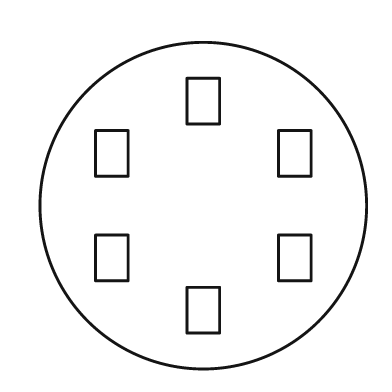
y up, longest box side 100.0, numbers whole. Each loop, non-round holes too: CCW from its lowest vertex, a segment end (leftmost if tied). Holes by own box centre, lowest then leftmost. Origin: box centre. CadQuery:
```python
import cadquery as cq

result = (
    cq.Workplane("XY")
    .moveTo(0.0, 0.0)
    .circle(50.0)
    .moveTo(-5.0, -39.0)
    .lineTo(5.0, -39.0)
    .lineTo(5.0, -25.0)
    .lineTo(-5.0, -25.0)
    .close()
    .moveTo(-33.0, -23.0)
    .lineTo(-23.0, -23.0)
    .lineTo(-23.0, -9.0)
    .lineTo(-33.0, -9.0)
    .close()
    .moveTo(23.0, -23.0)
    .lineTo(33.0, -23.0)
    .lineTo(33.0, -9.0)
    .lineTo(23.0, -9.0)
    .close()
    .moveTo(-33.0, 9.0)
    .lineTo(-23.0, 9.0)
    .lineTo(-23.0, 23.0)
    .lineTo(-33.0, 23.0)
    .close()
    .moveTo(23.0, 9.0)
    .lineTo(33.0, 9.0)
    .lineTo(33.0, 23.0)
    .lineTo(23.0, 23.0)
    .close()
    .moveTo(-5.0, 25.0)
    .lineTo(5.0, 25.0)
    .lineTo(5.0, 39.0)
    .lineTo(-5.0, 39.0)
    .close()
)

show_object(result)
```